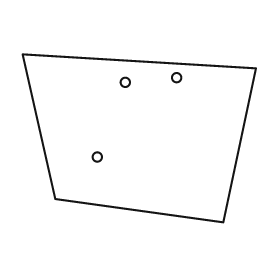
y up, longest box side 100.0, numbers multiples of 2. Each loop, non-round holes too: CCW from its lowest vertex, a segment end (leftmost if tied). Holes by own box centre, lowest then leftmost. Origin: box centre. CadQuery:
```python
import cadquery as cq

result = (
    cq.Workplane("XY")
    .moveTo(36.0, -36.0)
    .lineTo(50.0, 30.0)
    .lineTo(-50.0, 36.0)
    .lineTo(-36.0, -26.0)
    .close()
    .moveTo(-18.0, -8.0)
    .circle(2.0)
    .moveTo(-6.0, 24.0)
    .circle(2.0)
    .moveTo(16.0, 26.0)
    .circle(2.0)
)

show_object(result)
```